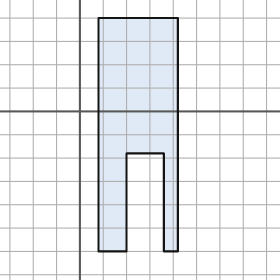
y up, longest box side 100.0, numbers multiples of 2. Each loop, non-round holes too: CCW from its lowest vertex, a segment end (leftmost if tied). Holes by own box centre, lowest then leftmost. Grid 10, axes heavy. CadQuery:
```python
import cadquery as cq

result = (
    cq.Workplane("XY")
    .moveTo(8.0, -60.0)
    .lineTo(20.0, -60.0)
    .lineTo(20.0, -18.0)
    .lineTo(36.0, -18.0)
    .lineTo(36.0, -60.0)
    .lineTo(42.0, -60.0)
    .lineTo(42.0, 40.0)
    .lineTo(8.0, 40.0)
    .close()
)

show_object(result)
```